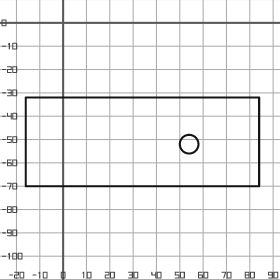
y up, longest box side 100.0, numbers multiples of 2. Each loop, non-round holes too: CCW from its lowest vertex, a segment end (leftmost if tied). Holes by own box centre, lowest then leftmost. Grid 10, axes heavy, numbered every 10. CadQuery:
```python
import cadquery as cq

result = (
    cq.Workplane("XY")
    .moveTo(-16.0, -70.0)
    .lineTo(84.0, -70.0)
    .lineTo(84.0, -32.0)
    .lineTo(-16.0, -32.0)
    .close()
    .moveTo(54.0, -52.0)
    .circle(4.0)
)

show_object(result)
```